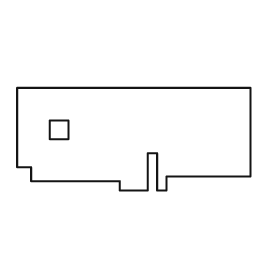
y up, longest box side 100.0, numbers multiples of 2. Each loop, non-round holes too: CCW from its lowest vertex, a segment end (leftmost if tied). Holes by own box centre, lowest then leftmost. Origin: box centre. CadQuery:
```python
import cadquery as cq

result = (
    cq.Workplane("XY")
    .moveTo(-6.0, -22.0)
    .lineTo(6.0, -22.0)
    .lineTo(6.0, -6.0)
    .lineTo(10.0, -6.0)
    .lineTo(10.0, -22.0)
    .lineTo(14.0, -22.0)
    .lineTo(14.0, -16.0)
    .lineTo(50.0, -16.0)
    .lineTo(50.0, 22.0)
    .lineTo(-50.0, 22.0)
    .lineTo(-50.0, -12.0)
    .lineTo(-44.0, -12.0)
    .lineTo(-44.0, -18.0)
    .lineTo(-6.0, -18.0)
    .close()
    .moveTo(-36.0, 0.0)
    .lineTo(-28.0, 0.0)
    .lineTo(-28.0, 8.0)
    .lineTo(-36.0, 8.0)
    .close()
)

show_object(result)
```